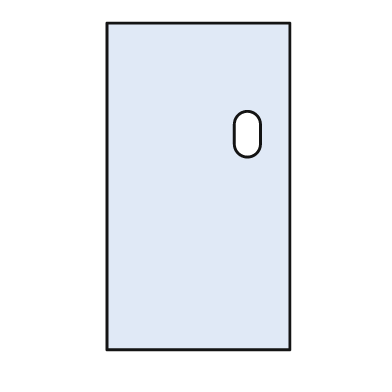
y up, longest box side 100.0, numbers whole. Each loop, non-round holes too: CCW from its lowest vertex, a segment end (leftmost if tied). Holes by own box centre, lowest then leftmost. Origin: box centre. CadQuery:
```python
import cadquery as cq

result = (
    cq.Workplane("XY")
    .moveTo(-28.0, -50.0)
    .lineTo(28.0, -50.0)
    .lineTo(28.0, 50.0)
    .lineTo(-28.0, 50.0)
    .close()
    .moveTo(11.0, 13.0)
    .threePointArc((15.0, 9.0), (19.0, 13.0))
    .lineTo(19.0, 19.0)
    .threePointArc((15.0, 23.0), (11.0, 19.0))
    .close()
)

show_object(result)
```